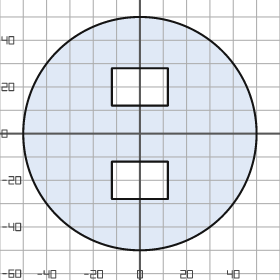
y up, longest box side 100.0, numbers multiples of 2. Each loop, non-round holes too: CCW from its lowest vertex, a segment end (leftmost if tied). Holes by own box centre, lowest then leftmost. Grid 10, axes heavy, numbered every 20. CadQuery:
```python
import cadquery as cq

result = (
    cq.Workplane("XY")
    .moveTo(0.0, 0.0)
    .circle(50.0)
    .moveTo(-12.0, -28.0)
    .lineTo(12.0, -28.0)
    .lineTo(12.0, -12.0)
    .lineTo(-12.0, -12.0)
    .close()
    .moveTo(-12.0, 12.0)
    .lineTo(12.0, 12.0)
    .lineTo(12.0, 28.0)
    .lineTo(-12.0, 28.0)
    .close()
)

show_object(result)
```